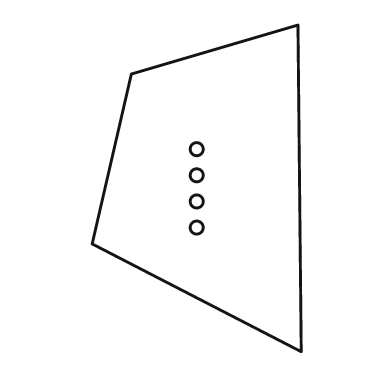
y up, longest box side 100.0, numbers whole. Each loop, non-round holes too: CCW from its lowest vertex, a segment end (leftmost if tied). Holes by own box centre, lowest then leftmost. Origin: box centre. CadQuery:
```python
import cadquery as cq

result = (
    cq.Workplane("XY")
    .moveTo(32.0, -50.0)
    .lineTo(31.0, 50.0)
    .lineTo(-20.0, 35.0)
    .lineTo(-32.0, -17.0)
    .close()
    .moveTo(0.0, -12.0)
    .circle(2.0)
    .moveTo(0.0, -4.0)
    .circle(2.0)
    .moveTo(0.0, 4.0)
    .circle(2.0)
    .moveTo(0.0, 12.0)
    .circle(2.0)
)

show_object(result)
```